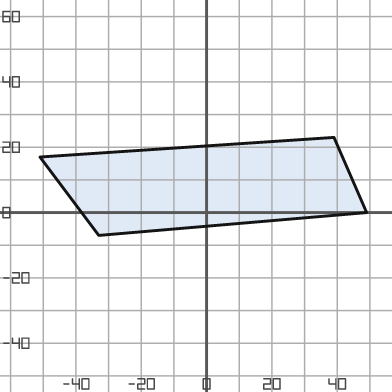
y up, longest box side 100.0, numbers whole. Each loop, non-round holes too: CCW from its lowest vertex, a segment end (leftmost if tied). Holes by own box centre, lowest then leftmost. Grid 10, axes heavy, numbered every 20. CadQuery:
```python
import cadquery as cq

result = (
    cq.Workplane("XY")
    .moveTo(-33.0, -7.0)
    .lineTo(49.0, 0.0)
    .lineTo(39.0, 23.0)
    .lineTo(-51.0, 17.0)
    .close()
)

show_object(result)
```